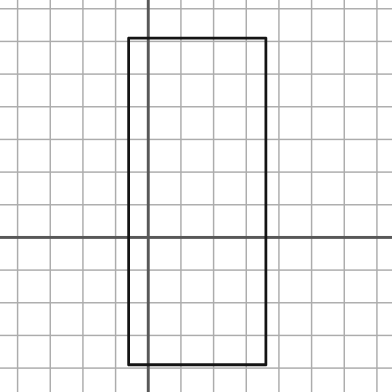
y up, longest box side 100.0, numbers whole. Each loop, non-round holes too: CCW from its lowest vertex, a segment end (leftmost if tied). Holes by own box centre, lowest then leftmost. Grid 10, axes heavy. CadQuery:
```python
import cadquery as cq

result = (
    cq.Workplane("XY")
    .moveTo(-6.0, -39.0)
    .lineTo(36.0, -39.0)
    .lineTo(36.0, 61.0)
    .lineTo(-6.0, 61.0)
    .close()
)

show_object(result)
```